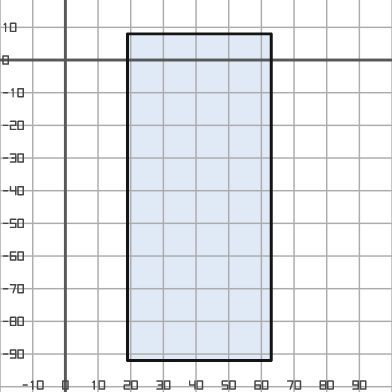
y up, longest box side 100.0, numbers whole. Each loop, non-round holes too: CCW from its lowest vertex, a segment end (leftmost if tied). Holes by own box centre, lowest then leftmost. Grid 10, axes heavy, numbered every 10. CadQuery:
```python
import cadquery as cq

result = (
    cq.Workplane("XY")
    .moveTo(19.0, -92.0)
    .lineTo(63.0, -92.0)
    .lineTo(63.0, 8.0)
    .lineTo(19.0, 8.0)
    .close()
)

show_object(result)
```